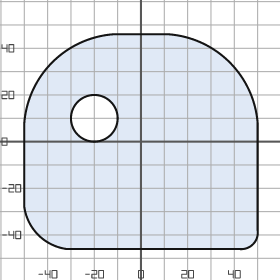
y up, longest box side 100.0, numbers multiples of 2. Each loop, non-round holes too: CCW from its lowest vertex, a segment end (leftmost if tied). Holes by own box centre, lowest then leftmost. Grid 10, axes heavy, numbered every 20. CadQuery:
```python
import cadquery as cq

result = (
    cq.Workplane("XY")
    .moveTo(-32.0, -46.0)
    .lineTo(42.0, -46.0)
    .threePointArc((48.0, -44.0), (50.0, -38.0))
    .lineTo(50.0, 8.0)
    .threePointArc((38.0, 34.0), (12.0, 46.0))
    .lineTo(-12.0, 46.0)
    .threePointArc((-38.0, 34.0), (-50.0, 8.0))
    .lineTo(-50.0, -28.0)
    .threePointArc((-44.0, -40.0), (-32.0, -46.0))
    .close()
    .moveTo(-20.0, 10.0)
    .circle(10.0)
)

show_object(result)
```